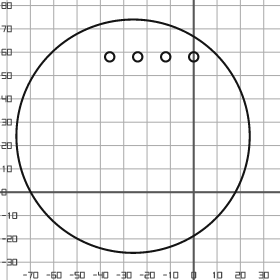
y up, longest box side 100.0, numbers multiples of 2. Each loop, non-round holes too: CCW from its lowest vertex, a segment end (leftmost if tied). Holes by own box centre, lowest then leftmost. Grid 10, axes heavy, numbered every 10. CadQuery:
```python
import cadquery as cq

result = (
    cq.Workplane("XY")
    .moveTo(-26.0, 24.0)
    .circle(50.0)
    .moveTo(-36.0, 58.0)
    .circle(2.0)
    .moveTo(-24.0, 58.0)
    .circle(2.0)
    .moveTo(-12.0, 58.0)
    .circle(2.0)
    .moveTo(0.0, 58.0)
    .circle(2.0)
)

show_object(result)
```